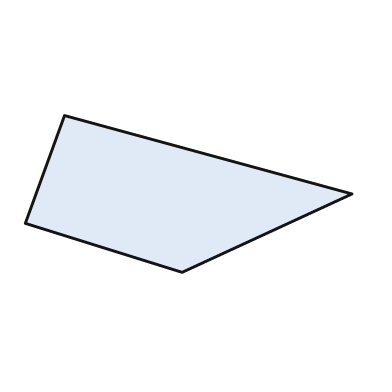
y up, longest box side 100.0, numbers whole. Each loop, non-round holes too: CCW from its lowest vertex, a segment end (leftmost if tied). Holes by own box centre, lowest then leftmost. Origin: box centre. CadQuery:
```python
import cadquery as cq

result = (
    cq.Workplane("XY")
    .moveTo(-2.0, -24.0)
    .lineTo(50.0, 0.0)
    .lineTo(-38.0, 24.0)
    .lineTo(-50.0, -9.0)
    .close()
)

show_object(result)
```